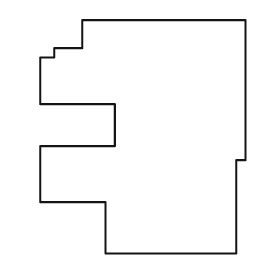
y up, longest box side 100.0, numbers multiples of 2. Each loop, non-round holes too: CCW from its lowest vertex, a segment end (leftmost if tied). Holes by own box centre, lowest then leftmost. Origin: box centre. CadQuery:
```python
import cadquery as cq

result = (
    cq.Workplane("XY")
    .moveTo(-16.0, -50.0)
    .lineTo(40.0, -50.0)
    .lineTo(40.0, -10.0)
    .lineTo(44.0, -10.0)
    .lineTo(44.0, 50.0)
    .lineTo(-26.0, 50.0)
    .lineTo(-26.0, 38.0)
    .lineTo(-38.0, 38.0)
    .lineTo(-38.0, 34.0)
    .lineTo(-44.0, 34.0)
    .lineTo(-44.0, 14.0)
    .lineTo(-12.0, 14.0)
    .lineTo(-12.0, -4.0)
    .lineTo(-44.0, -4.0)
    .lineTo(-44.0, -28.0)
    .lineTo(-16.0, -28.0)
    .close()
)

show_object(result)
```